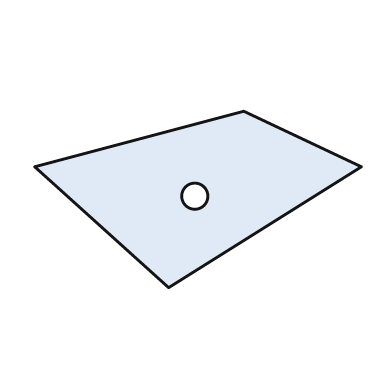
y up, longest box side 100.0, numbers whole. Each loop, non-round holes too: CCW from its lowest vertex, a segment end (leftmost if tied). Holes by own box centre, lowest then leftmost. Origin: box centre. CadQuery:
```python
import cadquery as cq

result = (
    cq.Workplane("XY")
    .moveTo(-9.0, -27.0)
    .lineTo(50.0, 10.0)
    .lineTo(14.0, 27.0)
    .lineTo(-50.0, 10.0)
    .close()
    .moveTo(-1.0, 1.0)
    .circle(4.0)
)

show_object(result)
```